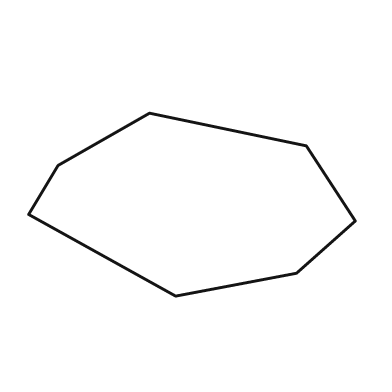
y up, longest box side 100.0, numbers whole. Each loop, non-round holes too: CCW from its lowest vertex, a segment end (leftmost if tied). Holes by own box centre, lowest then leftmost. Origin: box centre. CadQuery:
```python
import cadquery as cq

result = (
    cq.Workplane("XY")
    .moveTo(-5.0, -28.0)
    .lineTo(32.0, -21.0)
    .lineTo(50.0, -5.0)
    .lineTo(35.0, 18.0)
    .lineTo(-13.0, 28.0)
    .lineTo(-41.0, 12.0)
    .lineTo(-50.0, -3.0)
    .close()
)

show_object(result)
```